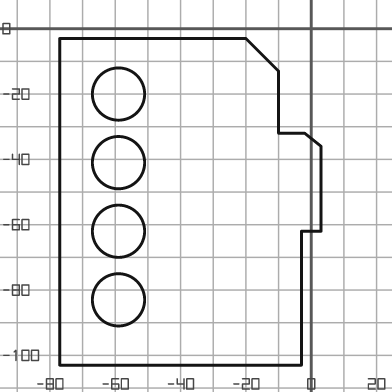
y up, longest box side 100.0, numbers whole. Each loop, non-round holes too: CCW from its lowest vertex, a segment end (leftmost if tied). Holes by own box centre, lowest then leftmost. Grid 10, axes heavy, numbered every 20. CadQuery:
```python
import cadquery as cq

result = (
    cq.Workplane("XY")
    .moveTo(-77.0, -103.0)
    .lineTo(-3.0, -103.0)
    .lineTo(-3.0, -62.0)
    .lineTo(3.0, -62.0)
    .lineTo(3.0, -36.0)
    .lineTo(-2.0, -32.0)
    .lineTo(-10.0, -32.0)
    .lineTo(-10.0, -13.0)
    .lineTo(-20.0, -3.0)
    .lineTo(-77.0, -3.0)
    .close()
    .moveTo(-59.0, -83.0)
    .circle(8.0)
    .moveTo(-59.0, -62.0)
    .circle(8.0)
    .moveTo(-59.0, -41.0)
    .circle(8.0)
    .moveTo(-59.0, -20.0)
    .circle(8.0)
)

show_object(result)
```